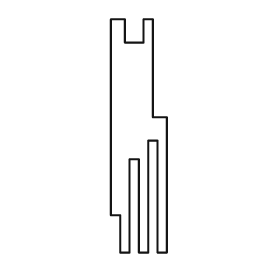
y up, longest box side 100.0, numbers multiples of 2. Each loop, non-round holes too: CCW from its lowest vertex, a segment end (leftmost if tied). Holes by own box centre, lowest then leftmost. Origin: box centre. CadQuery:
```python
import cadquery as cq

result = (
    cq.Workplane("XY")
    .moveTo(-8.0, -50.0)
    .lineTo(-4.0, -50.0)
    .lineTo(-4.0, -10.0)
    .lineTo(0.0, -10.0)
    .lineTo(0.0, -50.0)
    .lineTo(4.0, -50.0)
    .lineTo(4.0, -2.0)
    .lineTo(8.0, -2.0)
    .lineTo(8.0, -50.0)
    .lineTo(12.0, -50.0)
    .lineTo(12.0, 8.0)
    .lineTo(6.0, 8.0)
    .lineTo(6.0, 50.0)
    .lineTo(2.0, 50.0)
    .lineTo(2.0, 40.0)
    .lineTo(-6.0, 40.0)
    .lineTo(-6.0, 50.0)
    .lineTo(-12.0, 50.0)
    .lineTo(-12.0, -34.0)
    .lineTo(-8.0, -34.0)
    .close()
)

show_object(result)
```